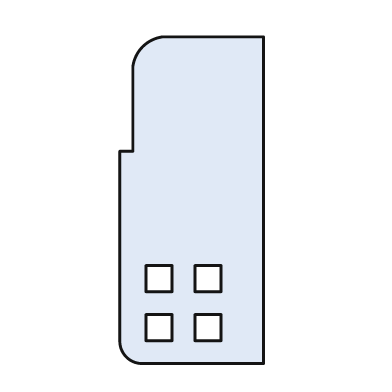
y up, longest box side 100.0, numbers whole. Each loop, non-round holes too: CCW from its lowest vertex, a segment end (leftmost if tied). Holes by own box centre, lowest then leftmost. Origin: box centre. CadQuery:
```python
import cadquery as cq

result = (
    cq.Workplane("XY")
    .moveTo(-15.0, -50.0)
    .lineTo(22.0, -50.0)
    .lineTo(22.0, 50.0)
    .lineTo(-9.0, 50.0)
    .threePointArc((-15.0, 47.0), (-18.0, 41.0))
    .lineTo(-18.0, 15.0)
    .lineTo(-22.0, 15.0)
    .lineTo(-22.0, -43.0)
    .threePointArc((-20.0, -48.0), (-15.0, -50.0))
    .close()
    .moveTo(-14.0, -43.0)
    .lineTo(-6.0, -43.0)
    .lineTo(-6.0, -35.0)
    .lineTo(-14.0, -35.0)
    .close()
    .moveTo(1.0, -43.0)
    .lineTo(9.0, -43.0)
    .lineTo(9.0, -35.0)
    .lineTo(1.0, -35.0)
    .close()
    .moveTo(-14.0, -28.0)
    .lineTo(-6.0, -28.0)
    .lineTo(-6.0, -20.0)
    .lineTo(-14.0, -20.0)
    .close()
    .moveTo(1.0, -28.0)
    .lineTo(9.0, -28.0)
    .lineTo(9.0, -20.0)
    .lineTo(1.0, -20.0)
    .close()
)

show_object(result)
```